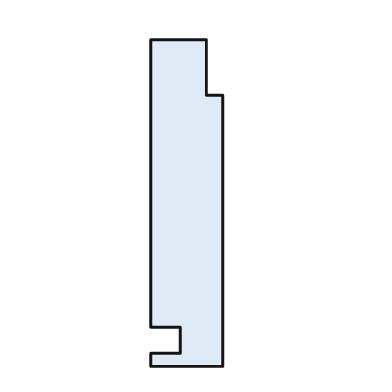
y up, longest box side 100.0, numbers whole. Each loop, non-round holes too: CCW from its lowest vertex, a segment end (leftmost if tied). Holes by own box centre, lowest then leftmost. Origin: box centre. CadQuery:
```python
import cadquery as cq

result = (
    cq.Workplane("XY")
    .moveTo(-11.0, -50.0)
    .lineTo(11.0, -50.0)
    .lineTo(11.0, 33.0)
    .lineTo(6.0, 33.0)
    .lineTo(6.0, 50.0)
    .lineTo(-11.0, 50.0)
    .lineTo(-11.0, -38.0)
    .lineTo(-2.0, -38.0)
    .lineTo(-2.0, -46.0)
    .lineTo(-11.0, -46.0)
    .close()
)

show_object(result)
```